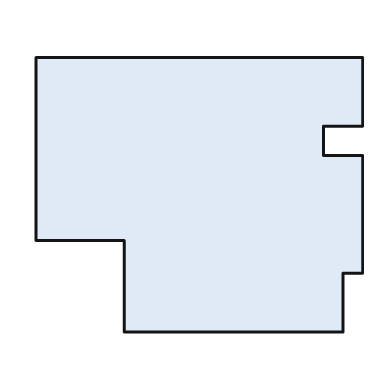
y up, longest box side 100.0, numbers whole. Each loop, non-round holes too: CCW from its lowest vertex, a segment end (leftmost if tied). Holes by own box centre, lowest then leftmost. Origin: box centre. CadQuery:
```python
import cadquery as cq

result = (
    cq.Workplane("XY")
    .moveTo(-23.0, -42.0)
    .lineTo(44.0, -42.0)
    .lineTo(44.0, -24.0)
    .lineTo(50.0, -24.0)
    .lineTo(50.0, 12.0)
    .lineTo(38.0, 12.0)
    .lineTo(38.0, 21.0)
    .lineTo(50.0, 21.0)
    .lineTo(50.0, 42.0)
    .lineTo(-50.0, 42.0)
    .lineTo(-50.0, -14.0)
    .lineTo(-23.0, -14.0)
    .close()
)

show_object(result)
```